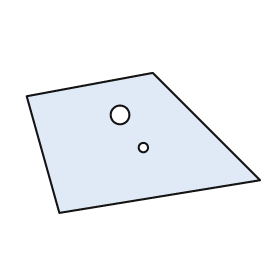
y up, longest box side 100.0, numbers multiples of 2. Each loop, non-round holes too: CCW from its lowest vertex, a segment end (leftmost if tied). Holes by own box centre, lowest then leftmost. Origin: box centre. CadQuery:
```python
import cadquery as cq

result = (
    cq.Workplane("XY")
    .moveTo(-36.0, -30.0)
    .lineTo(50.0, -16.0)
    .lineTo(4.0, 30.0)
    .lineTo(-50.0, 20.0)
    .close()
    .moveTo(0.0, -2.0)
    .circle(2.0)
    .moveTo(-10.0, 12.0)
    .circle(4.0)
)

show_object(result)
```